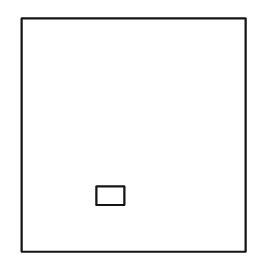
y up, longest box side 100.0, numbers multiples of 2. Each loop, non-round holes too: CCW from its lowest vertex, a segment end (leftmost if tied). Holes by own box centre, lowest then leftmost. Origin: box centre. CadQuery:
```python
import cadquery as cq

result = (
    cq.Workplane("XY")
    .moveTo(-48.0, -50.0)
    .lineTo(48.0, -50.0)
    .lineTo(48.0, 50.0)
    .lineTo(-48.0, 50.0)
    .close()
    .moveTo(-16.0, -30.0)
    .lineTo(-4.0, -30.0)
    .lineTo(-4.0, -22.0)
    .lineTo(-16.0, -22.0)
    .close()
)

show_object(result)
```